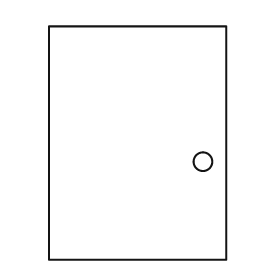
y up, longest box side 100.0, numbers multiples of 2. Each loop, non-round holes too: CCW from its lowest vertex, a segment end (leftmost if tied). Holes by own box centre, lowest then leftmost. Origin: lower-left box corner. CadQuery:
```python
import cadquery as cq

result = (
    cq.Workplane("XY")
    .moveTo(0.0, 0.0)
    .lineTo(76.0, 0.0)
    .lineTo(76.0, 100.0)
    .lineTo(0.0, 100.0)
    .close()
    .moveTo(66.0, 42.0)
    .circle(4.0)
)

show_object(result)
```